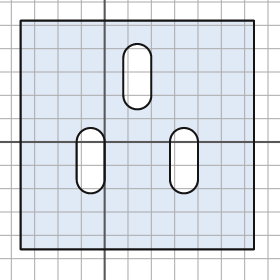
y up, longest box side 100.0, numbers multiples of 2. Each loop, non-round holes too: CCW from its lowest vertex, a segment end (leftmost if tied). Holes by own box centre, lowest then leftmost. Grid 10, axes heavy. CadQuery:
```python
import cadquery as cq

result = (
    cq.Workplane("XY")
    .moveTo(-36.0, -46.0)
    .lineTo(64.0, -46.0)
    .lineTo(64.0, 52.0)
    .lineTo(-36.0, 52.0)
    .close()
    .moveTo(-12.0, -16.0)
    .threePointArc((-6.0, -22.0), (0.0, -16.0))
    .lineTo(0.0, 0.0)
    .threePointArc((-6.0, 6.0), (-12.0, 0.0))
    .close()
    .moveTo(28.0, -16.0)
    .threePointArc((34.0, -22.0), (40.0, -16.0))
    .lineTo(40.0, 0.0)
    .threePointArc((34.0, 6.0), (28.0, 0.0))
    .close()
    .moveTo(8.0, 20.0)
    .threePointArc((14.0, 14.0), (20.0, 20.0))
    .lineTo(20.0, 36.0)
    .threePointArc((14.0, 42.0), (8.0, 36.0))
    .close()
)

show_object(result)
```